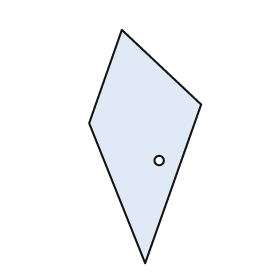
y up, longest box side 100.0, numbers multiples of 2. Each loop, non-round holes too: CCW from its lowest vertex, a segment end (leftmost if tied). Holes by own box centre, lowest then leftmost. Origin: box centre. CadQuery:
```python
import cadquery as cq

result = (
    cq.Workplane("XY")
    .moveTo(0.0, -50.0)
    .lineTo(24.0, 18.0)
    .lineTo(-10.0, 50.0)
    .lineTo(-24.0, 10.0)
    .close()
    .moveTo(6.0, -6.0)
    .circle(2.0)
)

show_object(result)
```